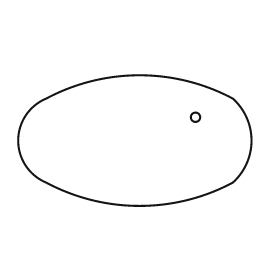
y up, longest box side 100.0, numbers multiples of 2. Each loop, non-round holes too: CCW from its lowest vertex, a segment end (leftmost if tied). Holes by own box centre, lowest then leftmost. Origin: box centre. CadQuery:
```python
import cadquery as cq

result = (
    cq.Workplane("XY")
    .moveTo(-38.0, -18.0)
    .threePointArc((2.0, -28.0), (42.0, -18.0))
    .threePointArc((50.0, 0.0), (42.0, 18.0))
    .threePointArc((2.0, 28.0), (-38.0, 18.0))
    .threePointArc((-50.0, 0.0), (-38.0, -18.0))
    .close()
    .moveTo(26.0, 10.0)
    .circle(2.0)
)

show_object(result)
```